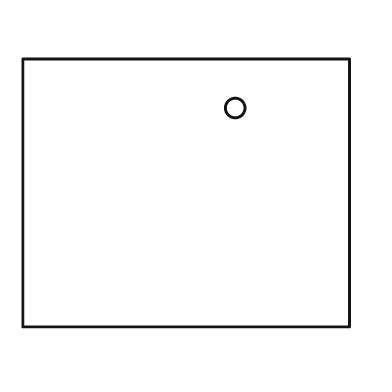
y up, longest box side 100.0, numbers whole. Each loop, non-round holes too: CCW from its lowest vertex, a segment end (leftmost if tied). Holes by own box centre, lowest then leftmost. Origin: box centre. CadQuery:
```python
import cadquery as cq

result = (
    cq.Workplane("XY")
    .moveTo(-50.0, -41.0)
    .lineTo(50.0, -41.0)
    .lineTo(50.0, 41.0)
    .lineTo(-50.0, 41.0)
    .close()
    .moveTo(15.0, 26.0)
    .circle(3.0)
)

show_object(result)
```